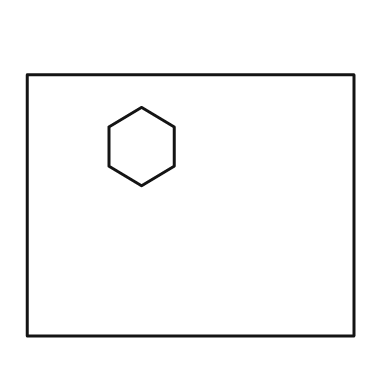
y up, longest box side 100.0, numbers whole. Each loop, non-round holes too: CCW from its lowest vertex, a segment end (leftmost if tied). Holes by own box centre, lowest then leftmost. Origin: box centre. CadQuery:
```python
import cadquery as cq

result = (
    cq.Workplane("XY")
    .moveTo(-50.0, -40.0)
    .lineTo(50.0, -40.0)
    .lineTo(50.0, 40.0)
    .lineTo(-50.0, 40.0)
    .close()
    .moveTo(-15.0, 6.0)
    .lineTo(-5.0, 12.0)
    .lineTo(-5.0, 24.0)
    .lineTo(-15.0, 30.0)
    .lineTo(-25.0, 24.0)
    .lineTo(-25.0, 12.0)
    .close()
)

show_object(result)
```